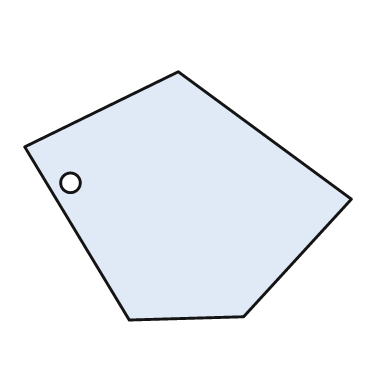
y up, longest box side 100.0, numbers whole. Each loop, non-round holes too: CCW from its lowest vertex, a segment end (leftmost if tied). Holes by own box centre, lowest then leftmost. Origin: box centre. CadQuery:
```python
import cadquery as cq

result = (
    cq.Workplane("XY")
    .moveTo(-18.0, -38.0)
    .lineTo(17.0, -37.0)
    .lineTo(50.0, -1.0)
    .lineTo(-3.0, 38.0)
    .lineTo(-50.0, 15.0)
    .close()
    .moveTo(-36.0, 4.0)
    .circle(3.0)
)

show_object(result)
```